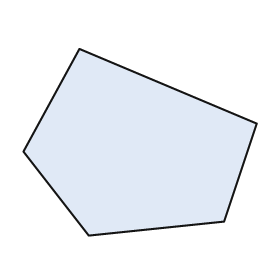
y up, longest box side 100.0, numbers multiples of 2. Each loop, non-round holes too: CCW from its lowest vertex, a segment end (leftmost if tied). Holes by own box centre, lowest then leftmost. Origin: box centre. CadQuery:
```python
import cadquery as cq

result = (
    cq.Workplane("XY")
    .moveTo(-22.0, -40.0)
    .lineTo(36.0, -34.0)
    .lineTo(50.0, 8.0)
    .lineTo(-26.0, 40.0)
    .lineTo(-50.0, -4.0)
    .close()
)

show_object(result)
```